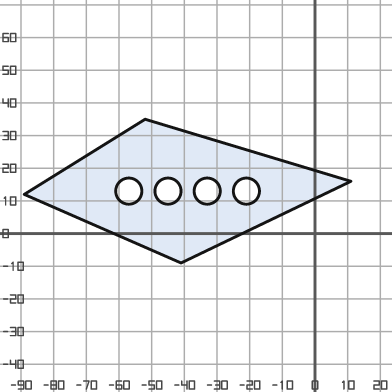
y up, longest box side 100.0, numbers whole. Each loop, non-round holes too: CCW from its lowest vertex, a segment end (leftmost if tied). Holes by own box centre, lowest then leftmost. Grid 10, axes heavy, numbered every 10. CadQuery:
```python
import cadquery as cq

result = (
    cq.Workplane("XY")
    .moveTo(-41.0, -9.0)
    .lineTo(11.0, 16.0)
    .lineTo(-52.0, 35.0)
    .lineTo(-89.0, 12.0)
    .close()
    .moveTo(-57.0, 13.0)
    .circle(4.0)
    .moveTo(-45.0, 13.0)
    .circle(4.0)
    .moveTo(-33.0, 13.0)
    .circle(4.0)
    .moveTo(-21.0, 13.0)
    .circle(4.0)
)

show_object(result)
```